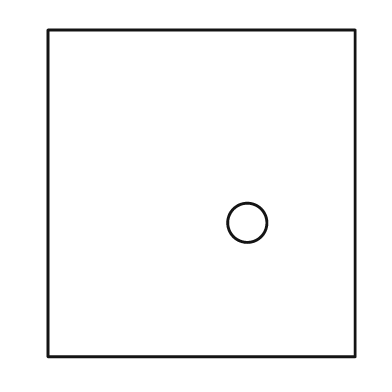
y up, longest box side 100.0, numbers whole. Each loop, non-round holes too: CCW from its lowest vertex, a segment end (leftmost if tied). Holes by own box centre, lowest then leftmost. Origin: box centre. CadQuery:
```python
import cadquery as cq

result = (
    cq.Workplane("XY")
    .moveTo(-47.0, -50.0)
    .lineTo(47.0, -50.0)
    .lineTo(47.0, 50.0)
    .lineTo(-47.0, 50.0)
    .close()
    .moveTo(14.0, -9.0)
    .circle(6.0)
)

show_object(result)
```